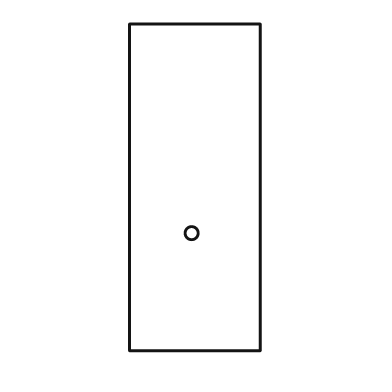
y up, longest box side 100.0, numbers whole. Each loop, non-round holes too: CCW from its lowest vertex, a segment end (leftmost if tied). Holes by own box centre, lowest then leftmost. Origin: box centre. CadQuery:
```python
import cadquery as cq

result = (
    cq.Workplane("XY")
    .moveTo(-20.0, -50.0)
    .lineTo(20.0, -50.0)
    .lineTo(20.0, 50.0)
    .lineTo(-20.0, 50.0)
    .close()
    .moveTo(-1.0, -14.0)
    .circle(2.0)
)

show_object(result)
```